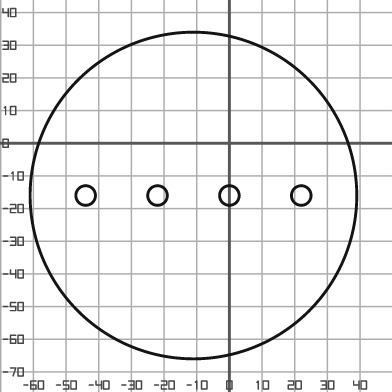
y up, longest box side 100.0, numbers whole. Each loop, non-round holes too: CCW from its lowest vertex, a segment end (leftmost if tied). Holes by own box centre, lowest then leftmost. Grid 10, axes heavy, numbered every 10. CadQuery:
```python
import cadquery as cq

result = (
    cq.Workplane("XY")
    .moveTo(-11.0, -16.0)
    .circle(50.0)
    .moveTo(-44.0, -16.0)
    .circle(3.0)
    .moveTo(-22.0, -16.0)
    .circle(3.0)
    .moveTo(0.0, -16.0)
    .circle(3.0)
    .moveTo(22.0, -16.0)
    .circle(3.0)
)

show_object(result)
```